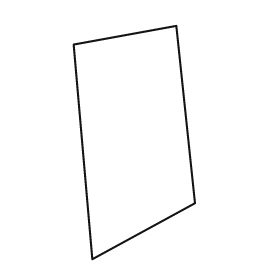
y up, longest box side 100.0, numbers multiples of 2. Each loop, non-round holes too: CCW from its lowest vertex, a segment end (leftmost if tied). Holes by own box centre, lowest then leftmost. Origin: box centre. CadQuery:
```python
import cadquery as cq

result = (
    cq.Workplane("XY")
    .moveTo(-18.0, -50.0)
    .lineTo(26.0, -26.0)
    .lineTo(18.0, 50.0)
    .lineTo(-26.0, 42.0)
    .close()
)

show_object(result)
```